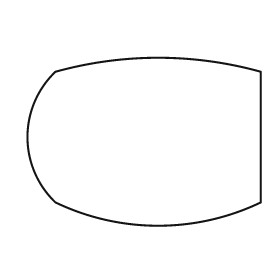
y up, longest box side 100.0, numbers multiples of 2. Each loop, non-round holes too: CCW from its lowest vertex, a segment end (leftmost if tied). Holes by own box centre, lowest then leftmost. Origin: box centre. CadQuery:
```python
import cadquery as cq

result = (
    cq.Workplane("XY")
    .moveTo(-38.0, -26.0)
    .threePointArc((6.0, -36.0), (50.0, -26.0))
    .lineTo(50.0, 30.0)
    .threePointArc((6.0, 36.0), (-38.0, 30.0))
    .threePointArc((-50.0, 2.0), (-38.0, -26.0))
    .close()
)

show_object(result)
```